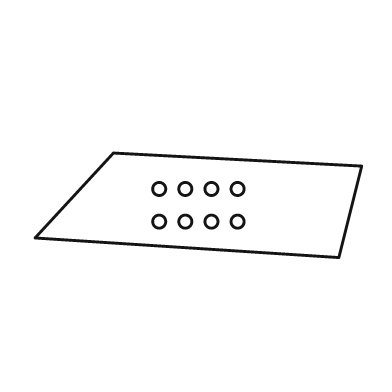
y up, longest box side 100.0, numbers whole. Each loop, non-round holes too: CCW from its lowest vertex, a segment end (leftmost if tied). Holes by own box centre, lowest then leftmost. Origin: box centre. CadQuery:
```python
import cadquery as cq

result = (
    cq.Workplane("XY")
    .moveTo(43.0, -16.0)
    .lineTo(50.0, 12.0)
    .lineTo(-26.0, 16.0)
    .lineTo(-50.0, -10.0)
    .close()
    .moveTo(-12.0, -5.0)
    .circle(2.0)
    .moveTo(-4.0, -5.0)
    .circle(2.0)
    .moveTo(4.0, -5.0)
    .circle(2.0)
    .moveTo(12.0, -5.0)
    .circle(2.0)
    .moveTo(-12.0, 5.0)
    .circle(2.0)
    .moveTo(-4.0, 5.0)
    .circle(2.0)
    .moveTo(4.0, 5.0)
    .circle(2.0)
    .moveTo(12.0, 5.0)
    .circle(2.0)
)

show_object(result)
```